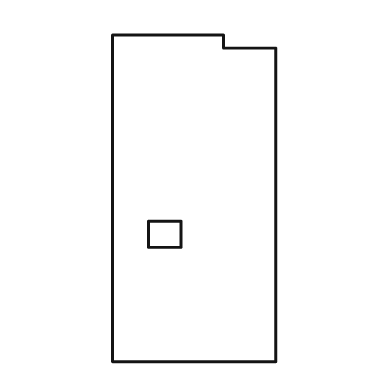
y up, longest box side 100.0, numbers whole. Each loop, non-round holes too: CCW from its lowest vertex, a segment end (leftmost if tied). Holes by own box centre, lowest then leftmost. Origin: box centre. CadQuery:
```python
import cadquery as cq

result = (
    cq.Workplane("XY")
    .moveTo(-25.0, -50.0)
    .lineTo(25.0, -50.0)
    .lineTo(25.0, 46.0)
    .lineTo(9.0, 46.0)
    .lineTo(9.0, 50.0)
    .lineTo(-25.0, 50.0)
    .close()
    .moveTo(-14.0, -15.0)
    .lineTo(-4.0, -15.0)
    .lineTo(-4.0, -7.0)
    .lineTo(-14.0, -7.0)
    .close()
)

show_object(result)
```